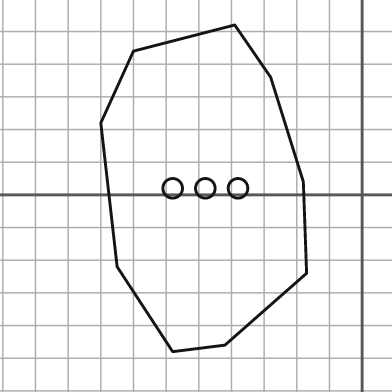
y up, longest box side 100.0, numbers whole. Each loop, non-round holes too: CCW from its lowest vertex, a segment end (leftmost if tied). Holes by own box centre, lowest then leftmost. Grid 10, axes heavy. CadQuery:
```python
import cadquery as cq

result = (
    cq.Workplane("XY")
    .moveTo(-58.0, -48.0)
    .lineTo(-42.0, -46.0)
    .lineTo(-17.0, -24.0)
    .lineTo(-18.0, 4.0)
    .lineTo(-28.0, 36.0)
    .lineTo(-39.0, 52.0)
    .lineTo(-70.0, 44.0)
    .lineTo(-80.0, 22.0)
    .lineTo(-75.0, -22.0)
    .close()
    .moveTo(-58.0, 2.0)
    .circle(3.0)
    .moveTo(-48.0, 2.0)
    .circle(3.0)
    .moveTo(-38.0, 2.0)
    .circle(3.0)
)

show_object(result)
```